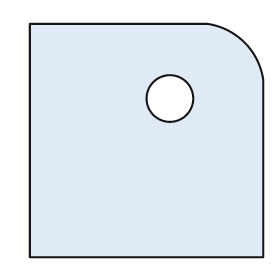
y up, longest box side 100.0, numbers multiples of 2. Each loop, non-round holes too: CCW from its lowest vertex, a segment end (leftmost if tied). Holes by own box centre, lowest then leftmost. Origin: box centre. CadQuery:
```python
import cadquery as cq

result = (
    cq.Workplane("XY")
    .moveTo(-50.0, -50.0)
    .lineTo(50.0, -50.0)
    .lineTo(50.0, 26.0)
    .threePointArc((42.0, 42.0), (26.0, 50.0))
    .lineTo(-50.0, 50.0)
    .close()
    .moveTo(10.0, 18.0)
    .circle(10.0)
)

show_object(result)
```